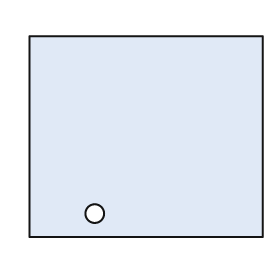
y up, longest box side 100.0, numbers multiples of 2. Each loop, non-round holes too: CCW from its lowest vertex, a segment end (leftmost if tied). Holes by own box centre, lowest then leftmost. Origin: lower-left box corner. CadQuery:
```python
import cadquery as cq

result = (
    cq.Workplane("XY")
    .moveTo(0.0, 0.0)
    .lineTo(100.0, 0.0)
    .lineTo(100.0, 86.0)
    .lineTo(0.0, 86.0)
    .close()
    .moveTo(28.0, 10.0)
    .circle(4.0)
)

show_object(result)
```